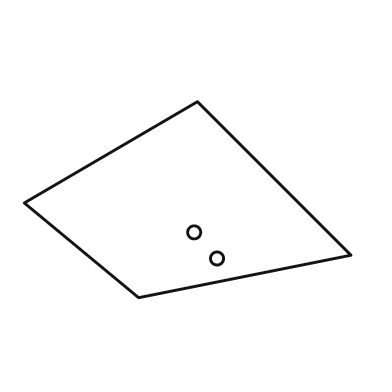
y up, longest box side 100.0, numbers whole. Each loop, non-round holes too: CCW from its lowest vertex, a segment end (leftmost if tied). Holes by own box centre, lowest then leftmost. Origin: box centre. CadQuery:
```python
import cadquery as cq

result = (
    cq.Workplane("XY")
    .moveTo(-15.0, -30.0)
    .lineTo(50.0, -17.0)
    .lineTo(3.0, 30.0)
    .lineTo(-50.0, -1.0)
    .close()
    .moveTo(9.0, -18.0)
    .circle(2.0)
    .moveTo(2.0, -10.0)
    .circle(2.0)
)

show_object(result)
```